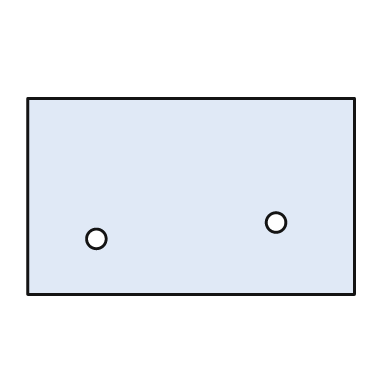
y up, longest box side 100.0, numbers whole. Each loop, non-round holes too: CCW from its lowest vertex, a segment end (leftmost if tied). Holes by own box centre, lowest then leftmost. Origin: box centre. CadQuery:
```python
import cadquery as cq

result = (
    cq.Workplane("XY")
    .moveTo(-50.0, -30.0)
    .lineTo(50.0, -30.0)
    .lineTo(50.0, 30.0)
    .lineTo(-50.0, 30.0)
    .close()
    .moveTo(-29.0, -13.0)
    .circle(3.0)
    .moveTo(26.0, -8.0)
    .circle(3.0)
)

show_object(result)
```